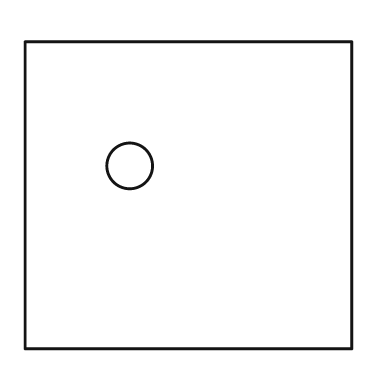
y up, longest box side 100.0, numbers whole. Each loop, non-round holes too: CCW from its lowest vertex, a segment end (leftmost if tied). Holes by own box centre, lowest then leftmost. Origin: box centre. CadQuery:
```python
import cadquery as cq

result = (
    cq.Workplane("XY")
    .moveTo(-50.0, -47.0)
    .lineTo(50.0, -47.0)
    .lineTo(50.0, 47.0)
    .lineTo(-50.0, 47.0)
    .close()
    .moveTo(-18.0, 9.0)
    .circle(7.0)
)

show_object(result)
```